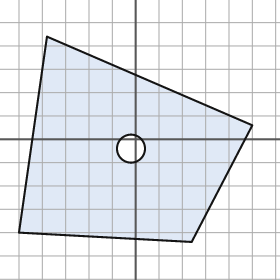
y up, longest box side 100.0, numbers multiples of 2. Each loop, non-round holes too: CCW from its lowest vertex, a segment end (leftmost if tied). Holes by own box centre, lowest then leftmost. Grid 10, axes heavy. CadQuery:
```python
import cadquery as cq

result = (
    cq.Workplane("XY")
    .moveTo(24.0, -44.0)
    .lineTo(50.0, 6.0)
    .lineTo(-38.0, 44.0)
    .lineTo(-50.0, -40.0)
    .close()
    .moveTo(-2.0, -4.0)
    .circle(6.0)
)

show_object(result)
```